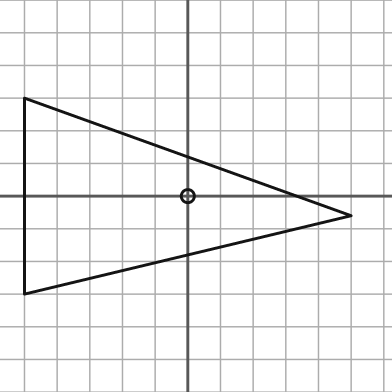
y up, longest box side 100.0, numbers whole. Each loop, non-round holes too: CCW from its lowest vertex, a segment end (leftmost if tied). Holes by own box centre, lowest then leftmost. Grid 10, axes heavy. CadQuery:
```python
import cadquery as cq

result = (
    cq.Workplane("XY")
    .moveTo(-50.0, -30.0)
    .lineTo(50.0, -6.0)
    .lineTo(-50.0, 30.0)
    .close()
    .moveTo(0.0, 0.0)
    .circle(2.0)
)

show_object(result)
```